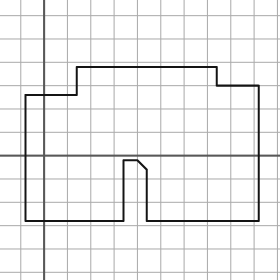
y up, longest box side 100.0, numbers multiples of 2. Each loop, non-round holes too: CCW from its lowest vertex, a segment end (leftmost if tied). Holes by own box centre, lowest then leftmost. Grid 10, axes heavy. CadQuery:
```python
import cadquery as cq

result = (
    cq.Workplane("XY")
    .moveTo(-8.0, -28.0)
    .lineTo(34.0, -28.0)
    .lineTo(34.0, -2.0)
    .lineTo(40.0, -2.0)
    .lineTo(44.0, -6.0)
    .lineTo(44.0, -28.0)
    .lineTo(92.0, -28.0)
    .lineTo(92.0, 30.0)
    .lineTo(74.0, 30.0)
    .lineTo(74.0, 38.0)
    .lineTo(14.0, 38.0)
    .lineTo(14.0, 26.0)
    .lineTo(-8.0, 26.0)
    .close()
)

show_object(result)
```